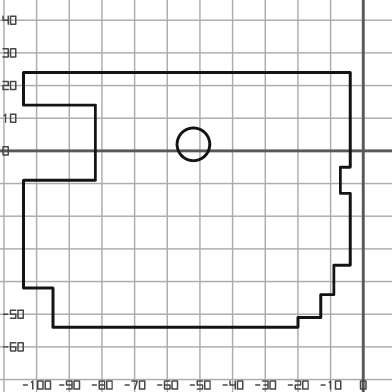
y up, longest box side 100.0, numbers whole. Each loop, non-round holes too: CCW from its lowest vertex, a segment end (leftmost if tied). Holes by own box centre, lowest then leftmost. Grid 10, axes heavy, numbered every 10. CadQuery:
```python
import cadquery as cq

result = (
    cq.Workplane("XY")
    .moveTo(-95.0, -54.0)
    .lineTo(-20.0, -54.0)
    .lineTo(-20.0, -51.0)
    .lineTo(-13.0, -51.0)
    .lineTo(-13.0, -44.0)
    .lineTo(-9.0, -44.0)
    .lineTo(-9.0, -35.0)
    .lineTo(-4.0, -35.0)
    .lineTo(-4.0, -13.0)
    .lineTo(-7.0, -13.0)
    .lineTo(-7.0, -5.0)
    .lineTo(-4.0, -5.0)
    .lineTo(-4.0, 24.0)
    .lineTo(-104.0, 24.0)
    .lineTo(-104.0, 14.0)
    .lineTo(-82.0, 14.0)
    .lineTo(-82.0, -9.0)
    .lineTo(-104.0, -9.0)
    .lineTo(-104.0, -42.0)
    .lineTo(-95.0, -42.0)
    .close()
    .moveTo(-52.0, 2.0)
    .circle(5.0)
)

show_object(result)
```